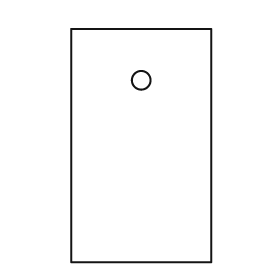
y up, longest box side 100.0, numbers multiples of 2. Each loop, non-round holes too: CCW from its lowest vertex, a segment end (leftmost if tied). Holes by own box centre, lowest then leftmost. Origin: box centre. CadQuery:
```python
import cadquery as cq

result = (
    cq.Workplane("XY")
    .moveTo(-30.0, -50.0)
    .lineTo(30.0, -50.0)
    .lineTo(30.0, 50.0)
    .lineTo(-30.0, 50.0)
    .close()
    .moveTo(0.0, 28.0)
    .circle(4.0)
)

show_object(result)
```